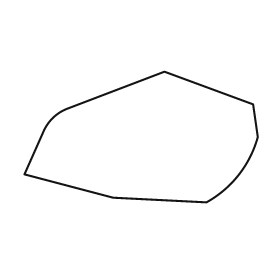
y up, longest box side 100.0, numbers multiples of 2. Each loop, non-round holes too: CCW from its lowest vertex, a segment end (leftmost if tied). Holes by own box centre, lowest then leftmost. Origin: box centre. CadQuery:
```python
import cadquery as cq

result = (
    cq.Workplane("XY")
    .moveTo(28.0, -28.0)
    .threePointArc((42.0, -16.0), (50.0, 0.0))
    .lineTo(48.0, 14.0)
    .lineTo(10.0, 28.0)
    .lineTo(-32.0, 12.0)
    .threePointArc((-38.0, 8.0), (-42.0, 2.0))
    .lineTo(-50.0, -16.0)
    .lineTo(-12.0, -26.0)
    .close()
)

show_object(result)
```